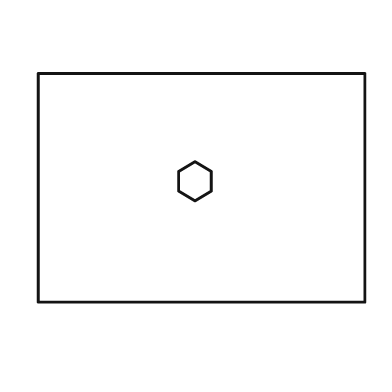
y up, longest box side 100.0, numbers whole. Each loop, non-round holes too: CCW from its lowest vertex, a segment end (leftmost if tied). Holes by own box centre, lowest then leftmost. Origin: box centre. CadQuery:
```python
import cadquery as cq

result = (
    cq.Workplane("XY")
    .moveTo(-50.0, -35.0)
    .lineTo(50.0, -35.0)
    .lineTo(50.0, 35.0)
    .lineTo(-50.0, 35.0)
    .close()
    .moveTo(-2.0, -4.0)
    .lineTo(3.0, -1.0)
    .lineTo(3.0, 5.0)
    .lineTo(-2.0, 8.0)
    .lineTo(-7.0, 5.0)
    .lineTo(-7.0, -1.0)
    .close()
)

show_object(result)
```